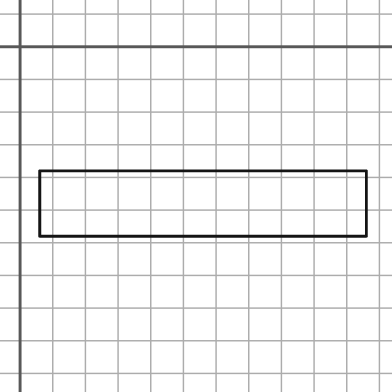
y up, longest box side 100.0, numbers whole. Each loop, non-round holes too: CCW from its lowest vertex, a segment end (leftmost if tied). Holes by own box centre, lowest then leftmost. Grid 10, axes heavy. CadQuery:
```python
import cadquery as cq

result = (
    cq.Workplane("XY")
    .moveTo(6.0, -58.0)
    .lineTo(106.0, -58.0)
    .lineTo(106.0, -38.0)
    .lineTo(6.0, -38.0)
    .close()
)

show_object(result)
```